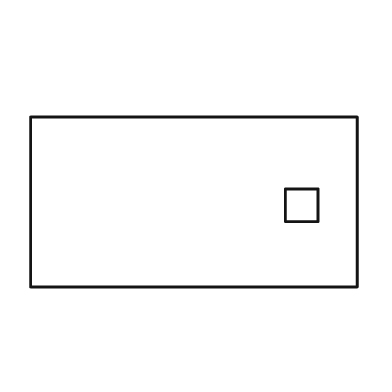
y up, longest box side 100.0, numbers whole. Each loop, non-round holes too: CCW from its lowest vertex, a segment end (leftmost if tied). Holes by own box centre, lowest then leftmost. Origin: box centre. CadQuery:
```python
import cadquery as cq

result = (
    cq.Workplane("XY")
    .moveTo(-50.0, -26.0)
    .lineTo(50.0, -26.0)
    .lineTo(50.0, 26.0)
    .lineTo(-50.0, 26.0)
    .close()
    .moveTo(28.0, -6.0)
    .lineTo(38.0, -6.0)
    .lineTo(38.0, 4.0)
    .lineTo(28.0, 4.0)
    .close()
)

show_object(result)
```